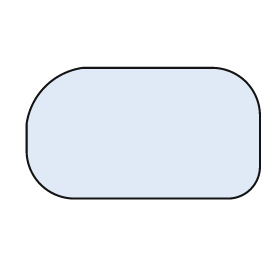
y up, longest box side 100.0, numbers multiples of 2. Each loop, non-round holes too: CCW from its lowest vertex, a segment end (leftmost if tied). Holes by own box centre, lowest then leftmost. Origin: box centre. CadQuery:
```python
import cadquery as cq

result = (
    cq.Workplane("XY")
    .moveTo(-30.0, -28.0)
    .lineTo(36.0, -28.0)
    .threePointArc((46.0, -24.0), (50.0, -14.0))
    .lineTo(50.0, 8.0)
    .threePointArc((44.0, 22.0), (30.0, 28.0))
    .lineTo(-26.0, 28.0)
    .threePointArc((-42.0, 20.0), (-50.0, 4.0))
    .lineTo(-50.0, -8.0)
    .threePointArc((-44.0, -22.0), (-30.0, -28.0))
    .close()
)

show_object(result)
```